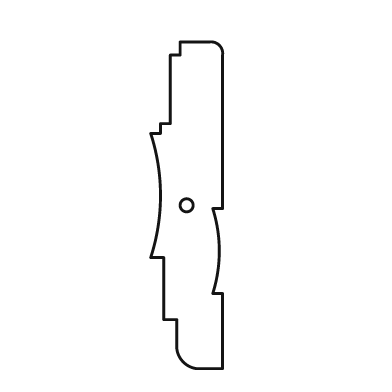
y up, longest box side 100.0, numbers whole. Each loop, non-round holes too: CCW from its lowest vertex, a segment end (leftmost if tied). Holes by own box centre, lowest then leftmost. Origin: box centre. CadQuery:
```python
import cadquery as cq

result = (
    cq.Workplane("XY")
    .moveTo(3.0, -50.0)
    .lineTo(11.0, -50.0)
    .lineTo(11.0, -27.0)
    .lineTo(8.0, -27.0)
    .threePointArc((10.0, -14.0), (8.0, -1.0))
    .lineTo(11.0, -1.0)
    .lineTo(11.0, 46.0)
    .threePointArc((10.0, 49.0), (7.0, 50.0))
    .lineTo(-2.0, 50.0)
    .lineTo(-2.0, 46.0)
    .lineTo(-5.0, 46.0)
    .lineTo(-5.0, 25.0)
    .lineTo(-8.0, 25.0)
    .lineTo(-8.0, 22.0)
    .lineTo(-11.0, 22.0)
    .threePointArc((-8.0, 3.0), (-11.0, -16.0))
    .lineTo(-7.0, -16.0)
    .lineTo(-7.0, -35.0)
    .lineTo(-3.0, -35.0)
    .lineTo(-3.0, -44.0)
    .threePointArc((-1.0, -48.0), (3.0, -50.0))
    .close()
    .moveTo(0.0, 0.0)
    .circle(2.0)
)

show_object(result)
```